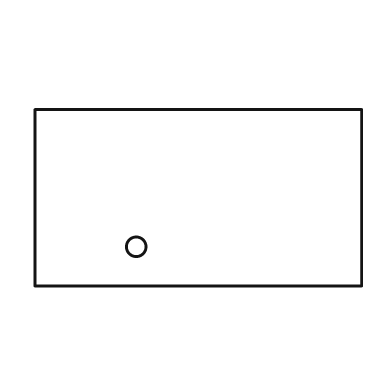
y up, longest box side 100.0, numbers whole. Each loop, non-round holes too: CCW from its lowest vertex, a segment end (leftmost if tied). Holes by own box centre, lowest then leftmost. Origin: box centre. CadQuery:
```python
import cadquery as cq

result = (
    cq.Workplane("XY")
    .moveTo(-50.0, -27.0)
    .lineTo(50.0, -27.0)
    .lineTo(50.0, 27.0)
    .lineTo(-50.0, 27.0)
    .close()
    .moveTo(-19.0, -15.0)
    .circle(3.0)
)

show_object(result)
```